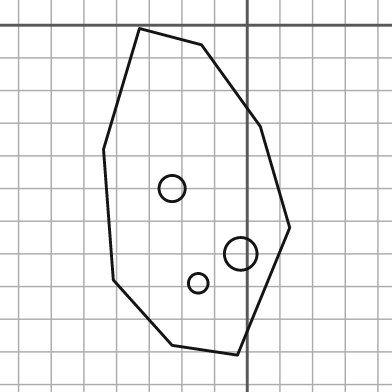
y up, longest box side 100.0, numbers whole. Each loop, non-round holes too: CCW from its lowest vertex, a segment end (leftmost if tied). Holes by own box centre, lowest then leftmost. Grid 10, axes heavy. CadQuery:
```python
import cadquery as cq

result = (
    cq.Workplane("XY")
    .moveTo(-3.0, -101.0)
    .lineTo(13.0, -62.0)
    .lineTo(4.0, -31.0)
    .lineTo(-14.0, -6.0)
    .lineTo(-33.0, -1.0)
    .lineTo(-44.0, -38.0)
    .lineTo(-41.0, -78.0)
    .lineTo(-23.0, -98.0)
    .close()
    .moveTo(-15.0, -79.0)
    .circle(3.0)
    .moveTo(-2.0, -70.0)
    .circle(5.0)
    .moveTo(-23.0, -50.0)
    .circle(4.0)
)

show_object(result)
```